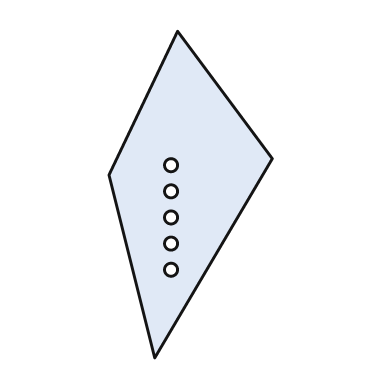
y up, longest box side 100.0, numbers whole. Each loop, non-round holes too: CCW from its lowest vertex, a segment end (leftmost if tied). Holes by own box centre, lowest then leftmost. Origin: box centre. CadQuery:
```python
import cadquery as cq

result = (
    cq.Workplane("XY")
    .moveTo(-11.0, -50.0)
    .lineTo(25.0, 11.0)
    .lineTo(-4.0, 50.0)
    .lineTo(-25.0, 6.0)
    .close()
    .moveTo(-6.0, -23.0)
    .circle(2.0)
    .moveTo(-6.0, -15.0)
    .circle(2.0)
    .moveTo(-6.0, -7.0)
    .circle(2.0)
    .moveTo(-6.0, 1.0)
    .circle(2.0)
    .moveTo(-6.0, 9.0)
    .circle(2.0)
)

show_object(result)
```